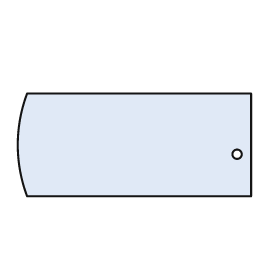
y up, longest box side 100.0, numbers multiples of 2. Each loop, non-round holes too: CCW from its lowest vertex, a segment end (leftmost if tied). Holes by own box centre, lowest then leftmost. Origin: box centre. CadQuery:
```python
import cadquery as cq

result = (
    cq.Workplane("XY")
    .moveTo(-46.0, -22.0)
    .lineTo(50.0, -22.0)
    .lineTo(50.0, 22.0)
    .lineTo(-46.0, 22.0)
    .threePointArc((-50.0, 0.0), (-46.0, -22.0))
    .close()
    .moveTo(44.0, -4.0)
    .circle(2.0)
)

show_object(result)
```